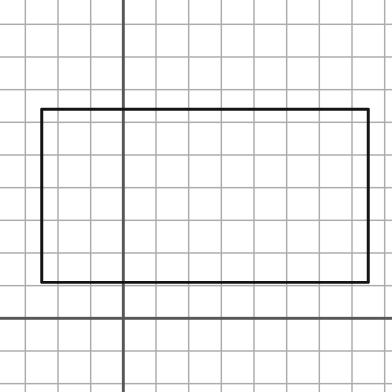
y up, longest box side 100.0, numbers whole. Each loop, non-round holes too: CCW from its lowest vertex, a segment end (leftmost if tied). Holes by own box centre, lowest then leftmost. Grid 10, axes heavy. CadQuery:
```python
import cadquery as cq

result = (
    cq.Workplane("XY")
    .moveTo(-25.0, 11.0)
    .lineTo(75.0, 11.0)
    .lineTo(75.0, 64.0)
    .lineTo(-25.0, 64.0)
    .close()
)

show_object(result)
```